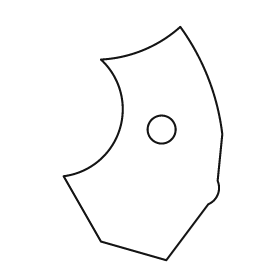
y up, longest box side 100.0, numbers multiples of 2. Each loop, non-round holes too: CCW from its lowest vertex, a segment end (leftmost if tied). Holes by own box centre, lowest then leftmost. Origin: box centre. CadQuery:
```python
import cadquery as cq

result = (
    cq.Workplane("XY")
    .moveTo(10.0, -50.0)
    .lineTo(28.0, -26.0)
    .threePointArc((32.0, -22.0), (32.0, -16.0))
    .lineTo(34.0, 4.0)
    .threePointArc((28.0, 28.0), (16.0, 50.0))
    .threePointArc((0.0, 40.0), (-18.0, 36.0))
    .threePointArc((-10.0, 6.0), (-34.0, -14.0))
    .lineTo(-18.0, -42.0)
    .close()
    .moveTo(8.0, 6.0)
    .circle(6.0)
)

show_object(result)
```